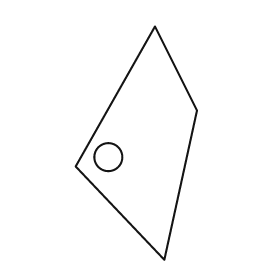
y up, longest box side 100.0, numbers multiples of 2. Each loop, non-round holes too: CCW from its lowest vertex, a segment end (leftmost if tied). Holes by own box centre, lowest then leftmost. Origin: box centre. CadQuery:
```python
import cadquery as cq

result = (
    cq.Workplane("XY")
    .moveTo(12.0, -50.0)
    .lineTo(26.0, 14.0)
    .lineTo(8.0, 50.0)
    .lineTo(-26.0, -10.0)
    .close()
    .moveTo(-12.0, -6.0)
    .circle(6.0)
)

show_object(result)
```